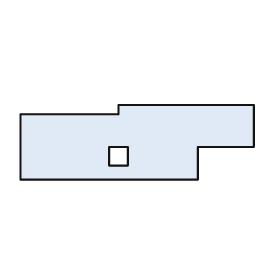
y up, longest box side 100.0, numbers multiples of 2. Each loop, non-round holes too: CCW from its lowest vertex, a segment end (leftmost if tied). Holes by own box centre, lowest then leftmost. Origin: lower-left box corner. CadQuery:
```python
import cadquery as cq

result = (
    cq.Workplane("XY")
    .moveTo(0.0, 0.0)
    .lineTo(76.0, 0.0)
    .lineTo(76.0, 14.0)
    .lineTo(100.0, 14.0)
    .lineTo(100.0, 32.0)
    .lineTo(42.0, 32.0)
    .lineTo(42.0, 28.0)
    .lineTo(0.0, 28.0)
    .close()
    .moveTo(38.0, 6.0)
    .lineTo(46.0, 6.0)
    .lineTo(46.0, 14.0)
    .lineTo(38.0, 14.0)
    .close()
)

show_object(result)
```